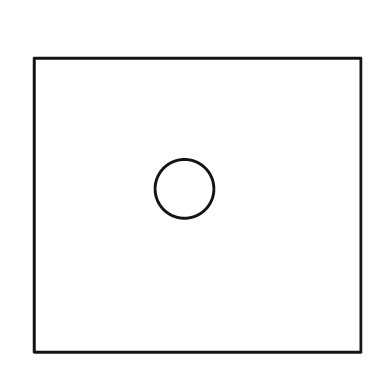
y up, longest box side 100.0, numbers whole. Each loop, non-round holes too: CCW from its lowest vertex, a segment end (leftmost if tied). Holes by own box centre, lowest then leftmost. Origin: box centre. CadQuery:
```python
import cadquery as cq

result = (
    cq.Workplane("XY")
    .moveTo(-50.0, -45.0)
    .lineTo(50.0, -45.0)
    .lineTo(50.0, 45.0)
    .lineTo(-50.0, 45.0)
    .close()
    .moveTo(-4.0, 5.0)
    .circle(9.0)
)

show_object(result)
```